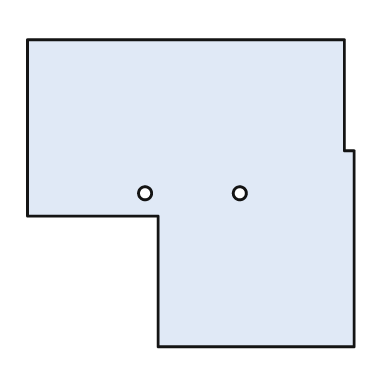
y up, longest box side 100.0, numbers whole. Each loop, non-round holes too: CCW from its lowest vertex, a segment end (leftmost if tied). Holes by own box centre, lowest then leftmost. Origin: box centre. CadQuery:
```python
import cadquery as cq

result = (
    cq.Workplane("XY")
    .moveTo(-10.0, -47.0)
    .lineTo(50.0, -47.0)
    .lineTo(50.0, 13.0)
    .lineTo(47.0, 13.0)
    .lineTo(47.0, 47.0)
    .lineTo(-50.0, 47.0)
    .lineTo(-50.0, -7.0)
    .lineTo(-10.0, -7.0)
    .close()
    .moveTo(-14.0, 0.0)
    .circle(2.0)
    .moveTo(15.0, 0.0)
    .circle(2.0)
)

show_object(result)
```